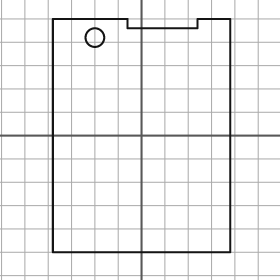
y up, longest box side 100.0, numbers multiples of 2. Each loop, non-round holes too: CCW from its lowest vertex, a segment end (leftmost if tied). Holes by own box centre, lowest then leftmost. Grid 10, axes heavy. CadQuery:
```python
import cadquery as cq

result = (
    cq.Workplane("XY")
    .moveTo(-38.0, -50.0)
    .lineTo(38.0, -50.0)
    .lineTo(38.0, 50.0)
    .lineTo(24.0, 50.0)
    .lineTo(24.0, 46.0)
    .lineTo(-6.0, 46.0)
    .lineTo(-6.0, 50.0)
    .lineTo(-38.0, 50.0)
    .close()
    .moveTo(-20.0, 42.0)
    .circle(4.0)
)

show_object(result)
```